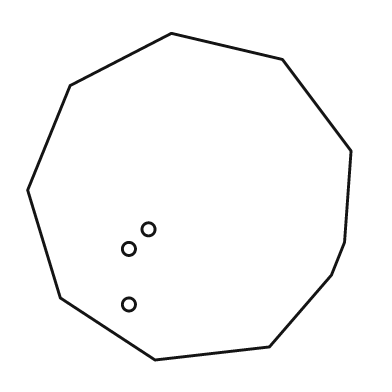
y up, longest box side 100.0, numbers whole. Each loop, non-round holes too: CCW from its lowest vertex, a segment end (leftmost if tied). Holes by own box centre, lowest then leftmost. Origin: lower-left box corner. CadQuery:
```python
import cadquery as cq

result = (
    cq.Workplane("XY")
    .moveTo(39.0, 0.0)
    .lineTo(74.0, 4.0)
    .lineTo(93.0, 26.0)
    .lineTo(97.0, 36.0)
    .lineTo(99.0, 64.0)
    .lineTo(78.0, 92.0)
    .lineTo(44.0, 100.0)
    .lineTo(13.0, 84.0)
    .lineTo(0.0, 52.0)
    .lineTo(10.0, 19.0)
    .close()
    .moveTo(31.0, 17.0)
    .circle(2.0)
    .moveTo(31.0, 34.0)
    .circle(2.0)
    .moveTo(37.0, 40.0)
    .circle(2.0)
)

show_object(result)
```